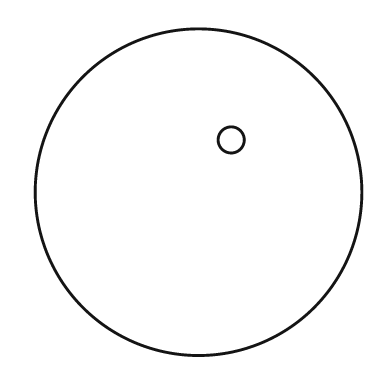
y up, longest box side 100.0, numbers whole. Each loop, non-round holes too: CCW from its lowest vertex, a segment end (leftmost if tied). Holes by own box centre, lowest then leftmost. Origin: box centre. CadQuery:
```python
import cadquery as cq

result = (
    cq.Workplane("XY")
    .moveTo(0.0, 0.0)
    .circle(50.0)
    .moveTo(10.0, 16.0)
    .circle(4.0)
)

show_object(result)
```